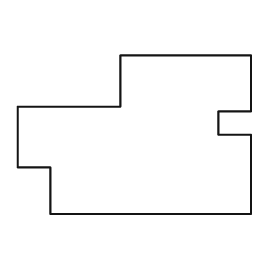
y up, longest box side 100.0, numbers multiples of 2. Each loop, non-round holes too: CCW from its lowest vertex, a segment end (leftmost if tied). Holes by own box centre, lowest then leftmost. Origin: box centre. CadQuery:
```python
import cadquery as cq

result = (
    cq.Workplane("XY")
    .moveTo(-36.0, -34.0)
    .lineTo(50.0, -34.0)
    .lineTo(50.0, 0.0)
    .lineTo(36.0, 0.0)
    .lineTo(36.0, 10.0)
    .lineTo(50.0, 10.0)
    .lineTo(50.0, 34.0)
    .lineTo(-6.0, 34.0)
    .lineTo(-6.0, 12.0)
    .lineTo(-50.0, 12.0)
    .lineTo(-50.0, -14.0)
    .lineTo(-36.0, -14.0)
    .close()
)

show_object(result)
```